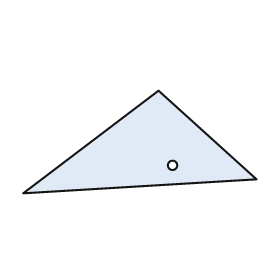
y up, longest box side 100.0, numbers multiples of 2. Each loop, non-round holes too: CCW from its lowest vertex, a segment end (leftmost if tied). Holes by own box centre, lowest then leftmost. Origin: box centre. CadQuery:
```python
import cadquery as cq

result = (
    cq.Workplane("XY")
    .moveTo(-50.0, -22.0)
    .lineTo(50.0, -16.0)
    .lineTo(8.0, 22.0)
    .close()
    .moveTo(14.0, -10.0)
    .circle(2.0)
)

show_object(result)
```